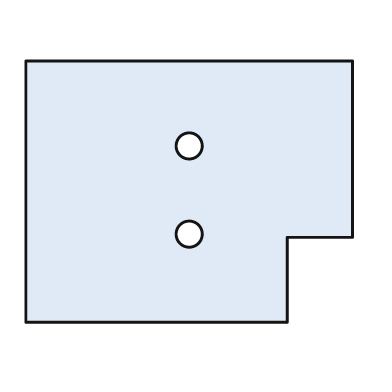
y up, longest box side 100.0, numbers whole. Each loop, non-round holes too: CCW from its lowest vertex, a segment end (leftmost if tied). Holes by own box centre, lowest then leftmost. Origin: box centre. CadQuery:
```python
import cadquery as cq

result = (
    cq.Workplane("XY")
    .moveTo(-50.0, -40.0)
    .lineTo(30.0, -40.0)
    .lineTo(30.0, -14.0)
    .lineTo(50.0, -14.0)
    .lineTo(50.0, 40.0)
    .lineTo(-50.0, 40.0)
    .close()
    .moveTo(0.0, -13.0)
    .circle(4.0)
    .moveTo(0.0, 14.0)
    .circle(4.0)
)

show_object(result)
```